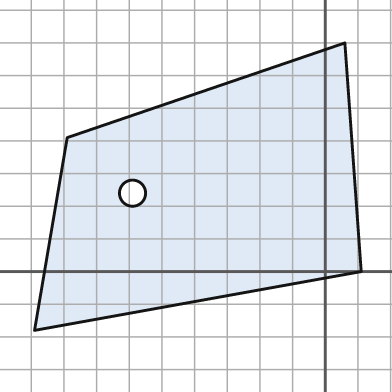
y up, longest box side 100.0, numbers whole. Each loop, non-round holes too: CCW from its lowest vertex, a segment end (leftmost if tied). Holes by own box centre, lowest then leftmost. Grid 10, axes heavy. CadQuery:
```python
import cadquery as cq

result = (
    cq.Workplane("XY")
    .moveTo(-89.0, -18.0)
    .lineTo(11.0, 0.0)
    .lineTo(6.0, 70.0)
    .lineTo(-79.0, 41.0)
    .close()
    .moveTo(-59.0, 24.0)
    .circle(4.0)
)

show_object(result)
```